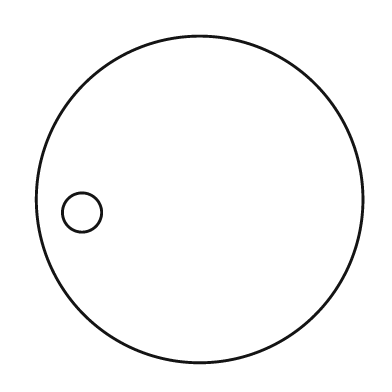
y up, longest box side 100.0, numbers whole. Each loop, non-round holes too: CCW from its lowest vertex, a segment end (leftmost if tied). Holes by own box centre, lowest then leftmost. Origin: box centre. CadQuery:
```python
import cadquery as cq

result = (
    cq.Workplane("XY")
    .moveTo(0.0, 0.0)
    .circle(50.0)
    .moveTo(-36.0, -4.0)
    .circle(6.0)
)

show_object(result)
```